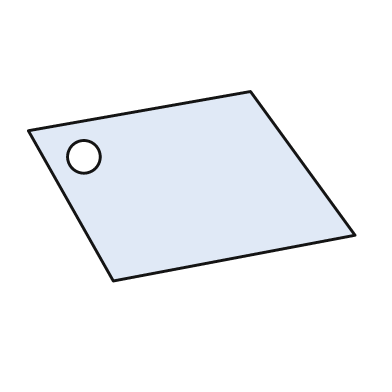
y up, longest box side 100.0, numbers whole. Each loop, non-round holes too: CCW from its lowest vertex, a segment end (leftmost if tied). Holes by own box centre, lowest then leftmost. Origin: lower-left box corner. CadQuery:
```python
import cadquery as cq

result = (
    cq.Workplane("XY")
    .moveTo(26.0, 0.0)
    .lineTo(100.0, 14.0)
    .lineTo(68.0, 58.0)
    .lineTo(0.0, 46.0)
    .close()
    .moveTo(17.0, 38.0)
    .circle(5.0)
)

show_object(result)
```